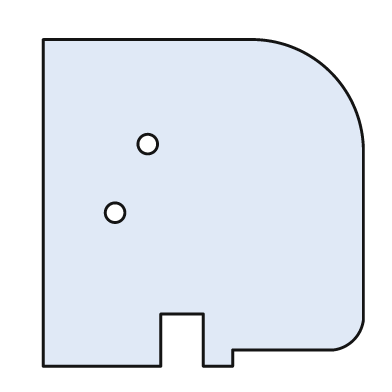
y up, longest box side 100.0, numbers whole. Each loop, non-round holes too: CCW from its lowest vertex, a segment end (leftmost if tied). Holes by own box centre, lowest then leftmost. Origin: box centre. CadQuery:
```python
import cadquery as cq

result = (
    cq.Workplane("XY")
    .moveTo(-49.0, -50.0)
    .lineTo(-13.0, -50.0)
    .lineTo(-13.0, -34.0)
    .lineTo(0.0, -34.0)
    .lineTo(0.0, -50.0)
    .lineTo(9.0, -50.0)
    .lineTo(9.0, -45.0)
    .lineTo(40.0, -45.0)
    .threePointArc((46.0, -42.0), (49.0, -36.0))
    .lineTo(49.0, 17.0)
    .threePointArc((39.0, 40.0), (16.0, 50.0))
    .lineTo(-49.0, 50.0)
    .close()
    .moveTo(-27.0, -3.0)
    .circle(3.0)
    .moveTo(-17.0, 18.0)
    .circle(3.0)
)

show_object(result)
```